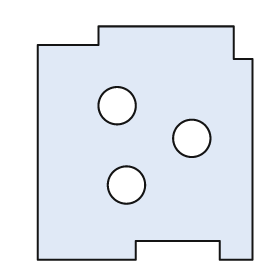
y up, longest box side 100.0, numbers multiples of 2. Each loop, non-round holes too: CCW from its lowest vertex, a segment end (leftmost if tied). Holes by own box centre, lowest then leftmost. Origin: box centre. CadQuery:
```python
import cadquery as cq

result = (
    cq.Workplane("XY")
    .moveTo(-46.0, -50.0)
    .lineTo(-4.0, -50.0)
    .lineTo(-4.0, -42.0)
    .lineTo(32.0, -42.0)
    .lineTo(32.0, -50.0)
    .lineTo(46.0, -50.0)
    .lineTo(46.0, 36.0)
    .lineTo(38.0, 36.0)
    .lineTo(38.0, 50.0)
    .lineTo(-20.0, 50.0)
    .lineTo(-20.0, 42.0)
    .lineTo(-46.0, 42.0)
    .close()
    .moveTo(-8.0, -18.0)
    .circle(8.0)
    .moveTo(20.0, 2.0)
    .circle(8.0)
    .moveTo(-12.0, 16.0)
    .circle(8.0)
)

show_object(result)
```